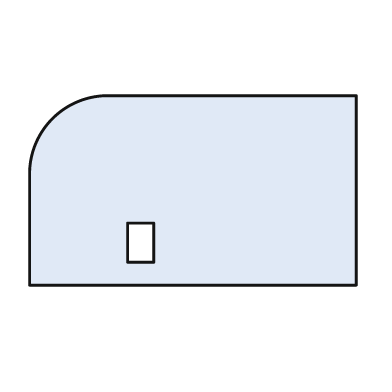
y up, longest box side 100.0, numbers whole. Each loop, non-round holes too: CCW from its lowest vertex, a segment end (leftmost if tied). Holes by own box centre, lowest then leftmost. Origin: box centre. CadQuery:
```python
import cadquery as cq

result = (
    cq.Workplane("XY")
    .moveTo(-50.0, -29.0)
    .lineTo(50.0, -29.0)
    .lineTo(50.0, 29.0)
    .lineTo(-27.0, 29.0)
    .threePointArc((-43.0, 22.0), (-50.0, 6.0))
    .close()
    .moveTo(-20.0, -22.0)
    .lineTo(-12.0, -22.0)
    .lineTo(-12.0, -10.0)
    .lineTo(-20.0, -10.0)
    .close()
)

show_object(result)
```